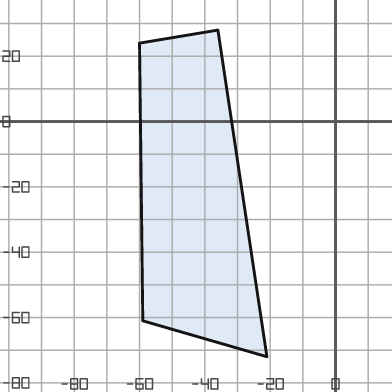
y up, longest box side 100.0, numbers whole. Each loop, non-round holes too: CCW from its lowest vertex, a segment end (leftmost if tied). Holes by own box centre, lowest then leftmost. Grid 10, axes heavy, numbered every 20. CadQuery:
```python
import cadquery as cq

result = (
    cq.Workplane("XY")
    .moveTo(-21.0, -72.0)
    .lineTo(-36.0, 28.0)
    .lineTo(-60.0, 24.0)
    .lineTo(-59.0, -61.0)
    .close()
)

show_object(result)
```